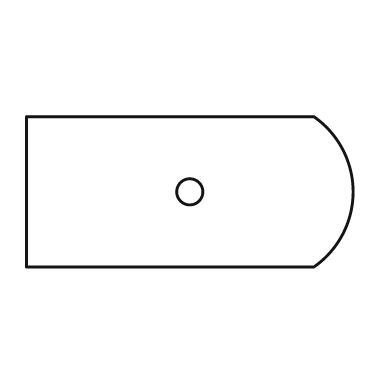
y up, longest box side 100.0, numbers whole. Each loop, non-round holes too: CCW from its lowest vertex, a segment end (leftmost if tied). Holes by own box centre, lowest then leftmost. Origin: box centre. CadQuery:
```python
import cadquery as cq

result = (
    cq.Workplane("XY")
    .moveTo(-50.0, -23.0)
    .lineTo(38.0, -23.0)
    .threePointArc((50.0, 0.0), (38.0, 23.0))
    .lineTo(-50.0, 23.0)
    .close()
    .moveTo(0.0, 0.0)
    .circle(4.0)
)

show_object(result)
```